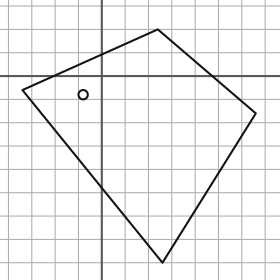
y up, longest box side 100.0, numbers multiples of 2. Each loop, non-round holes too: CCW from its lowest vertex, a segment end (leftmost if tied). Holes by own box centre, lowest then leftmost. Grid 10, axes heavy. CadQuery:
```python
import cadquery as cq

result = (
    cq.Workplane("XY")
    .moveTo(26.0, -80.0)
    .lineTo(66.0, -16.0)
    .lineTo(24.0, 20.0)
    .lineTo(-34.0, -6.0)
    .close()
    .moveTo(-8.0, -8.0)
    .circle(2.0)
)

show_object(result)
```